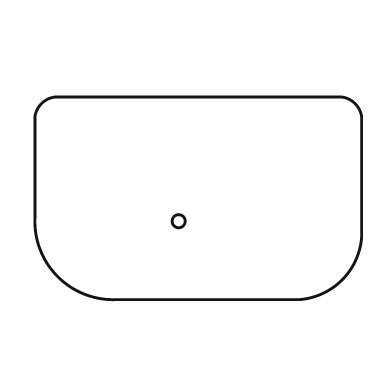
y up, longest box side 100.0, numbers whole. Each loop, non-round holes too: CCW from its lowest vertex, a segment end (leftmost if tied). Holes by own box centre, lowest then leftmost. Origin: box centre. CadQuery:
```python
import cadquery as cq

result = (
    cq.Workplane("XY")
    .moveTo(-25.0, -31.0)
    .lineTo(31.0, -31.0)
    .threePointArc((44.0, -25.0), (50.0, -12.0))
    .lineTo(50.0, 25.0)
    .threePointArc((48.0, 29.0), (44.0, 31.0))
    .lineTo(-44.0, 31.0)
    .threePointArc((-48.0, 29.0), (-50.0, 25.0))
    .lineTo(-50.0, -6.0)
    .threePointArc((-43.0, -24.0), (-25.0, -31.0))
    .close()
    .moveTo(-6.0, -7.0)
    .circle(2.0)
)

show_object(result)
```